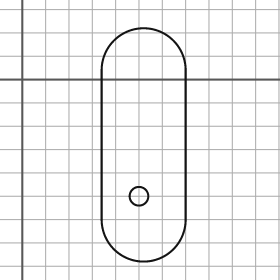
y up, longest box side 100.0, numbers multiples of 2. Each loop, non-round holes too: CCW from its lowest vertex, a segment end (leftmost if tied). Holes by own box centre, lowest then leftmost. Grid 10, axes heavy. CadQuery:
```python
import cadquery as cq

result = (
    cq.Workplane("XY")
    .moveTo(34.0, -60.0)
    .threePointArc((52.0, -78.0), (70.0, -60.0))
    .lineTo(70.0, 4.0)
    .threePointArc((52.0, 22.0), (34.0, 4.0))
    .close()
    .moveTo(50.0, -50.0)
    .circle(4.0)
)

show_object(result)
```